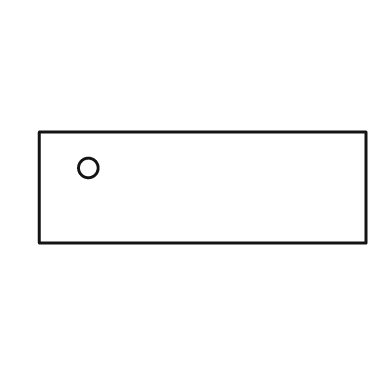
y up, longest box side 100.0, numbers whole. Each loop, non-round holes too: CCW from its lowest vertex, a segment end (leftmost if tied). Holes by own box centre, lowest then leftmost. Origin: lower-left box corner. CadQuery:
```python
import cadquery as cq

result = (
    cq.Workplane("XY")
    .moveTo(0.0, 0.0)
    .lineTo(100.0, 0.0)
    .lineTo(100.0, 34.0)
    .lineTo(0.0, 34.0)
    .close()
    .moveTo(15.0, 23.0)
    .circle(3.0)
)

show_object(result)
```